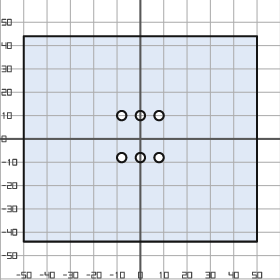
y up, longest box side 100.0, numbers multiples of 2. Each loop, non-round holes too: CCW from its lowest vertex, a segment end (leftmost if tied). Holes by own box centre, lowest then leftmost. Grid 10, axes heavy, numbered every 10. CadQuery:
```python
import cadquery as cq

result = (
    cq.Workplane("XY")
    .moveTo(-50.0, -44.0)
    .lineTo(50.0, -44.0)
    .lineTo(50.0, 44.0)
    .lineTo(-50.0, 44.0)
    .close()
    .moveTo(-8.0, -8.0)
    .circle(2.0)
    .moveTo(0.0, -8.0)
    .circle(2.0)
    .moveTo(8.0, -8.0)
    .circle(2.0)
    .moveTo(-8.0, 10.0)
    .circle(2.0)
    .moveTo(0.0, 10.0)
    .circle(2.0)
    .moveTo(8.0, 10.0)
    .circle(2.0)
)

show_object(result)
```